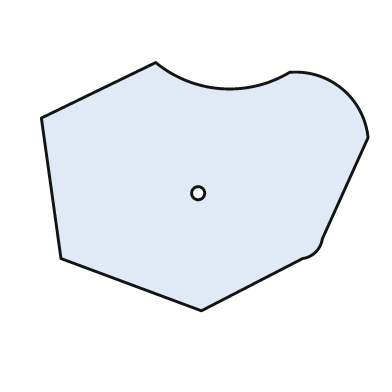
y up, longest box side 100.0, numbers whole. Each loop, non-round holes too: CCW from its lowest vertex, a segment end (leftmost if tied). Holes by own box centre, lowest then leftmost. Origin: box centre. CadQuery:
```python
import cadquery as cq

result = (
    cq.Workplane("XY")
    .moveTo(-1.0, -38.0)
    .lineTo(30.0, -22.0)
    .threePointArc((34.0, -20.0), (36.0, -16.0))
    .lineTo(50.0, 15.0)
    .threePointArc((42.0, 30.0), (26.0, 35.0))
    .threePointArc((5.0, 30.0), (-15.0, 38.0))
    .lineTo(-50.0, 21.0)
    .lineTo(-44.0, -22.0)
    .close()
    .moveTo(-2.0, -2.0)
    .circle(2.0)
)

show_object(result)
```